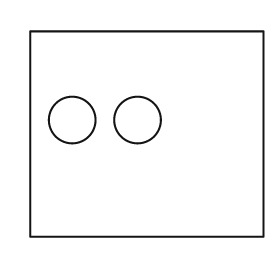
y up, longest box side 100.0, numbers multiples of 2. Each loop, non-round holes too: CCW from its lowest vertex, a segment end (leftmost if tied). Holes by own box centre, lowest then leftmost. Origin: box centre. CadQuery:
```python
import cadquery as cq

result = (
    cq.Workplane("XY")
    .moveTo(-50.0, -44.0)
    .lineTo(50.0, -44.0)
    .lineTo(50.0, 44.0)
    .lineTo(-50.0, 44.0)
    .close()
    .moveTo(-32.0, 6.0)
    .circle(10.0)
    .moveTo(-4.0, 6.0)
    .circle(10.0)
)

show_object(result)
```